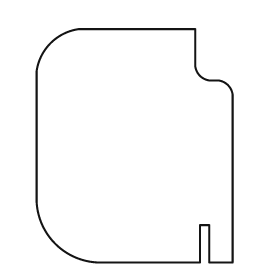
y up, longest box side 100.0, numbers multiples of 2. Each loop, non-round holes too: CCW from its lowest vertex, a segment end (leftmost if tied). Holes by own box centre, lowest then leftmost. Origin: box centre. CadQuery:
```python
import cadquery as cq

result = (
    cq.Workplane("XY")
    .moveTo(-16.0, -50.0)
    .lineTo(28.0, -50.0)
    .lineTo(28.0, -34.0)
    .lineTo(32.0, -34.0)
    .lineTo(32.0, -50.0)
    .lineTo(42.0, -50.0)
    .lineTo(42.0, 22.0)
    .threePointArc((40.0, 26.0), (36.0, 28.0))
    .lineTo(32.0, 28.0)
    .threePointArc((28.0, 30.0), (26.0, 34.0))
    .lineTo(26.0, 50.0)
    .lineTo(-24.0, 50.0)
    .threePointArc((-36.0, 44.0), (-42.0, 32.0))
    .lineTo(-42.0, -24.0)
    .threePointArc((-34.0, -42.0), (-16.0, -50.0))
    .close()
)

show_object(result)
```